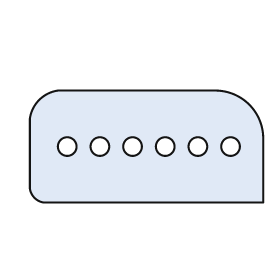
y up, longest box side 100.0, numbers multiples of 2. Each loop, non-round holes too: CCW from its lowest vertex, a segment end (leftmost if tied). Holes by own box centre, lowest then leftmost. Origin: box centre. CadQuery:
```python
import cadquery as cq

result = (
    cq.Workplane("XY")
    .moveTo(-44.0, -24.0)
    .lineTo(50.0, -24.0)
    .lineTo(50.0, 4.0)
    .threePointArc((44.0, 18.0), (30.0, 24.0))
    .lineTo(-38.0, 24.0)
    .threePointArc((-46.0, 20.0), (-50.0, 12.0))
    .lineTo(-50.0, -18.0)
    .threePointArc((-48.0, -22.0), (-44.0, -24.0))
    .close()
    .moveTo(-34.0, 0.0)
    .circle(4.0)
    .moveTo(-20.0, 0.0)
    .circle(4.0)
    .moveTo(-6.0, 0.0)
    .circle(4.0)
    .moveTo(8.0, 0.0)
    .circle(4.0)
    .moveTo(22.0, 0.0)
    .circle(4.0)
    .moveTo(36.0, 0.0)
    .circle(4.0)
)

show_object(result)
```